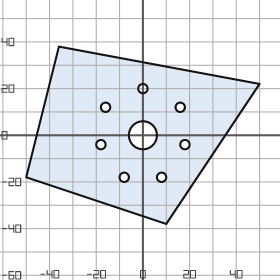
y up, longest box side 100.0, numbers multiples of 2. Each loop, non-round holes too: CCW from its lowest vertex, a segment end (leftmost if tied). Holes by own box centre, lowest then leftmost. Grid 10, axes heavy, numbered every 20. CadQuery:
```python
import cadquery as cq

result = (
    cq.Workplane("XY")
    .moveTo(10.0, -38.0)
    .lineTo(50.0, 22.0)
    .lineTo(-36.0, 38.0)
    .lineTo(-50.0, -18.0)
    .close()
    .moveTo(-8.0, -18.0)
    .circle(2.0)
    .moveTo(8.0, -18.0)
    .circle(2.0)
    .moveTo(-18.0, -4.0)
    .circle(2.0)
    .moveTo(18.0, -4.0)
    .circle(2.0)
    .moveTo(0.0, 0.0)
    .circle(6.0)
    .moveTo(-16.0, 12.0)
    .circle(2.0)
    .moveTo(16.0, 12.0)
    .circle(2.0)
    .moveTo(0.0, 20.0)
    .circle(2.0)
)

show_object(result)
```